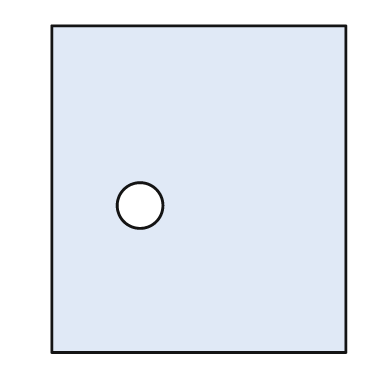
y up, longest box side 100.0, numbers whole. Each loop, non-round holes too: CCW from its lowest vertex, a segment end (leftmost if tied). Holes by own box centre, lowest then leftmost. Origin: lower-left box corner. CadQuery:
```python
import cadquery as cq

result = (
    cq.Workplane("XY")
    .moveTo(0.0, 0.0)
    .lineTo(90.0, 0.0)
    .lineTo(90.0, 100.0)
    .lineTo(0.0, 100.0)
    .close()
    .moveTo(27.0, 45.0)
    .circle(7.0)
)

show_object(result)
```